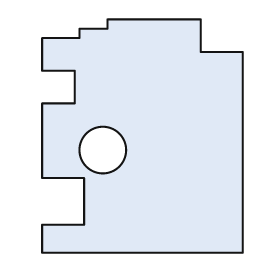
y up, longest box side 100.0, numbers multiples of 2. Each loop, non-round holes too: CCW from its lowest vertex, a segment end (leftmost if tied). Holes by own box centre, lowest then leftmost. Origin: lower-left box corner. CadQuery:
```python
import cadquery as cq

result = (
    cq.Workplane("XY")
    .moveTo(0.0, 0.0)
    .lineTo(86.0, 0.0)
    .lineTo(86.0, 86.0)
    .lineTo(68.0, 86.0)
    .lineTo(68.0, 100.0)
    .lineTo(28.0, 100.0)
    .lineTo(28.0, 96.0)
    .lineTo(16.0, 96.0)
    .lineTo(16.0, 92.0)
    .lineTo(0.0, 92.0)
    .lineTo(0.0, 78.0)
    .lineTo(14.0, 78.0)
    .lineTo(14.0, 64.0)
    .lineTo(0.0, 64.0)
    .lineTo(0.0, 32.0)
    .lineTo(18.0, 32.0)
    .lineTo(18.0, 12.0)
    .lineTo(0.0, 12.0)
    .close()
    .moveTo(26.0, 44.0)
    .circle(10.0)
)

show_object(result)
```